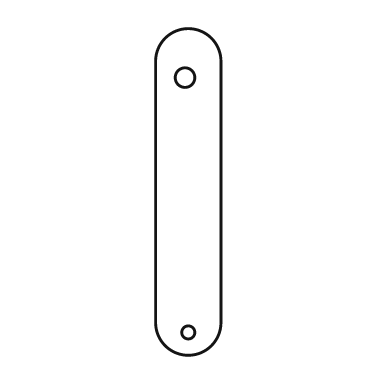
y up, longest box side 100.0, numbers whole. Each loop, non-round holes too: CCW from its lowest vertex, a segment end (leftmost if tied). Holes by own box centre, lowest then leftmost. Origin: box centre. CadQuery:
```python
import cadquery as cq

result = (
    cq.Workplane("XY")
    .moveTo(-10.0, -40.0)
    .threePointArc((0.0, -50.0), (10.0, -40.0))
    .lineTo(10.0, 40.0)
    .threePointArc((0.0, 50.0), (-10.0, 40.0))
    .close()
    .moveTo(0.0, -43.0)
    .circle(2.0)
    .moveTo(-1.0, 35.0)
    .circle(3.0)
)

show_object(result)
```